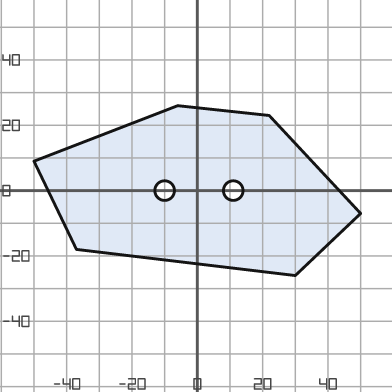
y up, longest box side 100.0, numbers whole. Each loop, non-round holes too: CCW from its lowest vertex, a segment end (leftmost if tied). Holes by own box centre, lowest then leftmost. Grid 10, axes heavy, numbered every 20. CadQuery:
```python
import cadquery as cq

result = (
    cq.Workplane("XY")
    .moveTo(30.0, -26.0)
    .lineTo(50.0, -7.0)
    .lineTo(22.0, 23.0)
    .lineTo(-6.0, 26.0)
    .lineTo(-50.0, 9.0)
    .lineTo(-37.0, -18.0)
    .close()
    .moveTo(-10.0, 0.0)
    .circle(3.0)
    .moveTo(11.0, 0.0)
    .circle(3.0)
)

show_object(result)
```